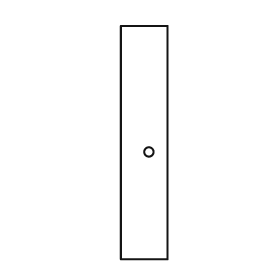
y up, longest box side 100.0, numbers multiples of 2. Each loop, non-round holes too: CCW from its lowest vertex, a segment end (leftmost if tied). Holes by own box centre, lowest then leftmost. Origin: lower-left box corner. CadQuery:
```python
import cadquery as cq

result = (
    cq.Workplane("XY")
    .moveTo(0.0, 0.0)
    .lineTo(20.0, 0.0)
    .lineTo(20.0, 100.0)
    .lineTo(0.0, 100.0)
    .close()
    .moveTo(12.0, 46.0)
    .circle(2.0)
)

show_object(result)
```